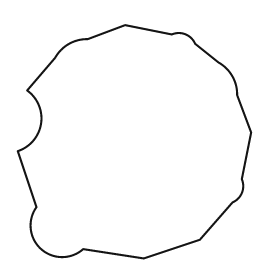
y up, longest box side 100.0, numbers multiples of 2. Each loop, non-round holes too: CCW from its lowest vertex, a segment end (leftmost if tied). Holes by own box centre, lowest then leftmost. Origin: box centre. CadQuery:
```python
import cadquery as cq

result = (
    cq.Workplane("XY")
    .moveTo(4.0, -50.0)
    .lineTo(28.0, -42.0)
    .lineTo(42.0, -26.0)
    .threePointArc((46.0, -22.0), (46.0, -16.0))
    .lineTo(50.0, 4.0)
    .lineTo(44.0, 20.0)
    .threePointArc((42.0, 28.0), (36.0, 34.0))
    .lineTo(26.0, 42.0)
    .threePointArc((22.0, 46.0), (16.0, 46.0))
    .lineTo(-4.0, 50.0)
    .lineTo(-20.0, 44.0)
    .threePointArc((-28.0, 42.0), (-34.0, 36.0))
    .lineTo(-46.0, 22.0)
    .threePointArc((-40.0, 8.0), (-50.0, -4.0))
    .lineTo(-42.0, -28.0)
    .threePointArc((-40.0, -46.0), (-22.0, -46.0))
    .close()
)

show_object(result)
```